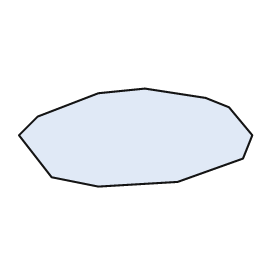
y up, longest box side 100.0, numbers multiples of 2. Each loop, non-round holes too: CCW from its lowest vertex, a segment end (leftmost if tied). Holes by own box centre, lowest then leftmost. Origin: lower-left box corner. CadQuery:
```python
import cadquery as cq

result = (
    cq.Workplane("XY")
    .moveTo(34.0, 0.0)
    .lineTo(68.0, 2.0)
    .lineTo(96.0, 12.0)
    .lineTo(100.0, 22.0)
    .lineTo(90.0, 34.0)
    .lineTo(80.0, 38.0)
    .lineTo(54.0, 42.0)
    .lineTo(34.0, 40.0)
    .lineTo(8.0, 30.0)
    .lineTo(0.0, 22.0)
    .lineTo(14.0, 4.0)
    .close()
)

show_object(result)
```